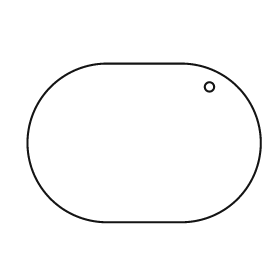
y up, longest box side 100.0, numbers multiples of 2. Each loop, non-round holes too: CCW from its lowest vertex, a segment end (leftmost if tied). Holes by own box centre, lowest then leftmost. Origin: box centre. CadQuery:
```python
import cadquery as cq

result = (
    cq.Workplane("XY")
    .moveTo(-16.0, -34.0)
    .lineTo(16.0, -34.0)
    .threePointArc((50.0, 0.0), (16.0, 34.0))
    .lineTo(-16.0, 34.0)
    .threePointArc((-50.0, 0.0), (-16.0, -34.0))
    .close()
    .moveTo(28.0, 24.0)
    .circle(2.0)
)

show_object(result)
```